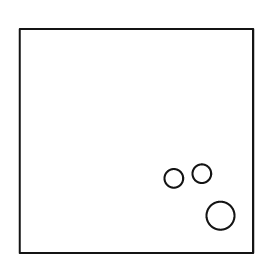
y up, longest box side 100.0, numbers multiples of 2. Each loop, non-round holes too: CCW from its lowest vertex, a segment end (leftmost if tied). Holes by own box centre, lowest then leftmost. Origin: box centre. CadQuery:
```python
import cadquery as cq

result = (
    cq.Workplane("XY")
    .moveTo(-50.0, -48.0)
    .lineTo(50.0, -48.0)
    .lineTo(50.0, 48.0)
    .lineTo(-50.0, 48.0)
    .close()
    .moveTo(36.0, -32.0)
    .circle(6.0)
    .moveTo(16.0, -16.0)
    .circle(4.0)
    .moveTo(28.0, -14.0)
    .circle(4.0)
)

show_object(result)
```